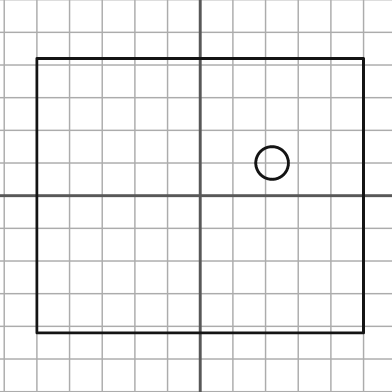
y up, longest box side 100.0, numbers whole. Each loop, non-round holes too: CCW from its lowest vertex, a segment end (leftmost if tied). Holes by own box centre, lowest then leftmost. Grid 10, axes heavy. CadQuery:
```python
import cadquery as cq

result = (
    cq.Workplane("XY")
    .moveTo(-50.0, -42.0)
    .lineTo(50.0, -42.0)
    .lineTo(50.0, 42.0)
    .lineTo(-50.0, 42.0)
    .close()
    .moveTo(22.0, 10.0)
    .circle(5.0)
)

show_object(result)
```